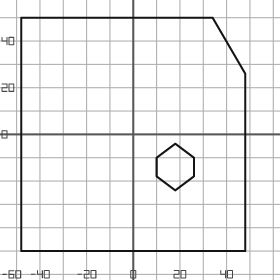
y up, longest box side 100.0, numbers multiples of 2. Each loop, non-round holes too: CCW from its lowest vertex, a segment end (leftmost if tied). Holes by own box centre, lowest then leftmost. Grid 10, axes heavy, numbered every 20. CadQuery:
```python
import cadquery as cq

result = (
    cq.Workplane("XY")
    .moveTo(-48.0, -50.0)
    .lineTo(48.0, -50.0)
    .lineTo(48.0, 26.0)
    .lineTo(34.0, 50.0)
    .lineTo(-48.0, 50.0)
    .close()
    .moveTo(18.0, -24.0)
    .lineTo(26.0, -18.0)
    .lineTo(26.0, -10.0)
    .lineTo(18.0, -4.0)
    .lineTo(10.0, -10.0)
    .lineTo(10.0, -18.0)
    .close()
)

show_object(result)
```